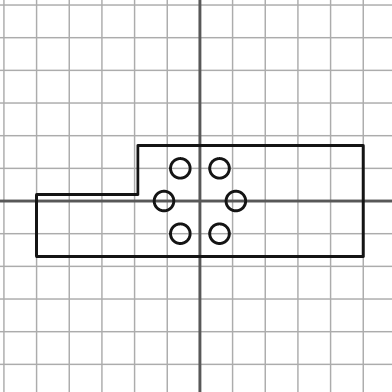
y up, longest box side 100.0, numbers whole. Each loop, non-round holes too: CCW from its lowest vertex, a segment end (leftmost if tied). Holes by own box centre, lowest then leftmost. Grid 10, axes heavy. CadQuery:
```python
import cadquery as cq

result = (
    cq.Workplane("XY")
    .moveTo(-50.0, -17.0)
    .lineTo(50.0, -17.0)
    .lineTo(50.0, 17.0)
    .lineTo(-19.0, 17.0)
    .lineTo(-19.0, 2.0)
    .lineTo(-50.0, 2.0)
    .close()
    .moveTo(-6.0, -10.0)
    .circle(3.0)
    .moveTo(6.0, -10.0)
    .circle(3.0)
    .moveTo(-11.0, 0.0)
    .circle(3.0)
    .moveTo(11.0, 0.0)
    .circle(3.0)
    .moveTo(-6.0, 10.0)
    .circle(3.0)
    .moveTo(6.0, 10.0)
    .circle(3.0)
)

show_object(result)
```